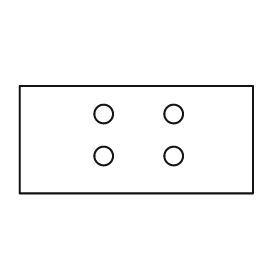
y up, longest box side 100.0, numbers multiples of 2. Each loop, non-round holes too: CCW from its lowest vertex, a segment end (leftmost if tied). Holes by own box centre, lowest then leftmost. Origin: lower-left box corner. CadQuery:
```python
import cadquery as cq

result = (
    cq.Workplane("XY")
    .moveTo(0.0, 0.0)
    .lineTo(100.0, 0.0)
    .lineTo(100.0, 46.0)
    .lineTo(0.0, 46.0)
    .close()
    .moveTo(36.0, 16.0)
    .circle(4.0)
    .moveTo(66.0, 16.0)
    .circle(4.0)
    .moveTo(36.0, 34.0)
    .circle(4.0)
    .moveTo(66.0, 34.0)
    .circle(4.0)
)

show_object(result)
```